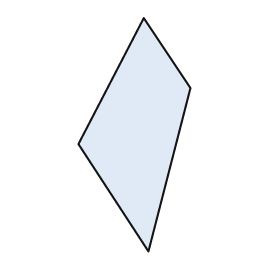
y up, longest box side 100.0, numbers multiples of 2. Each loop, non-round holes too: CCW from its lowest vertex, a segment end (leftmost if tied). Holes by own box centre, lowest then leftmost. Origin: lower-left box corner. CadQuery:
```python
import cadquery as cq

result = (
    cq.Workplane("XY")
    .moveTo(30.0, 0.0)
    .lineTo(48.0, 70.0)
    .lineTo(28.0, 100.0)
    .lineTo(0.0, 46.0)
    .close()
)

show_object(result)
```